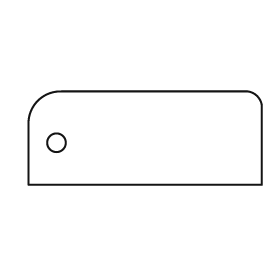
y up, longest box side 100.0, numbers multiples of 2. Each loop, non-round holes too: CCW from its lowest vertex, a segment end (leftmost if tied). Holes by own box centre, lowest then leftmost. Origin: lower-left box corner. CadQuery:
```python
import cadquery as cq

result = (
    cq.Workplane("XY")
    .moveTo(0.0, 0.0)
    .lineTo(100.0, 0.0)
    .lineTo(100.0, 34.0)
    .threePointArc((98.0, 38.0), (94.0, 40.0))
    .lineTo(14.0, 40.0)
    .threePointArc((4.0, 36.0), (0.0, 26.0))
    .close()
    .moveTo(12.0, 18.0)
    .circle(4.0)
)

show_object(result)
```